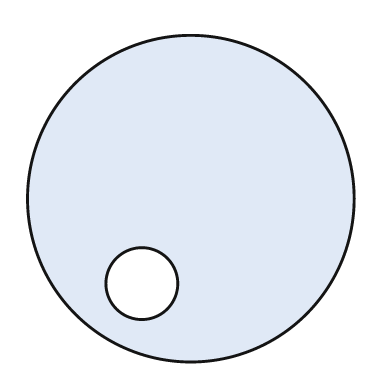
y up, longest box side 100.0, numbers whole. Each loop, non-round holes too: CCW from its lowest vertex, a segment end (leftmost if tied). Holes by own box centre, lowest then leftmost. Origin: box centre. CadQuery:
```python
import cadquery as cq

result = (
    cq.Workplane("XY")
    .moveTo(0.0, 0.0)
    .circle(50.0)
    .moveTo(-15.0, -26.0)
    .circle(11.0)
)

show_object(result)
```